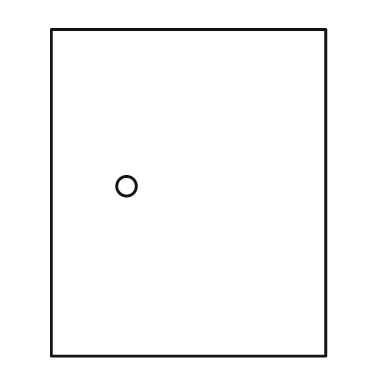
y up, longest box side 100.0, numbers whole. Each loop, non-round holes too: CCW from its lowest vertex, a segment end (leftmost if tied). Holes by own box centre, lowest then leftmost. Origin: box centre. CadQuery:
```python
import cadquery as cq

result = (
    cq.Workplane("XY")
    .moveTo(-42.0, -50.0)
    .lineTo(42.0, -50.0)
    .lineTo(42.0, 50.0)
    .lineTo(-42.0, 50.0)
    .close()
    .moveTo(-19.0, 2.0)
    .circle(3.0)
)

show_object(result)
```